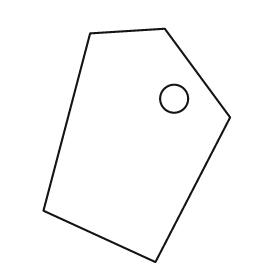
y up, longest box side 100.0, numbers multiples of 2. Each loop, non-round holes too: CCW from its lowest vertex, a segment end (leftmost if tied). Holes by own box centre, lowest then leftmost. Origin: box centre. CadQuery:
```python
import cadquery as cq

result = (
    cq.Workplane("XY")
    .moveTo(8.0, -50.0)
    .lineTo(40.0, 12.0)
    .lineTo(12.0, 50.0)
    .lineTo(-20.0, 48.0)
    .lineTo(-40.0, -28.0)
    .close()
    .moveTo(16.0, 20.0)
    .circle(6.0)
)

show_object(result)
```